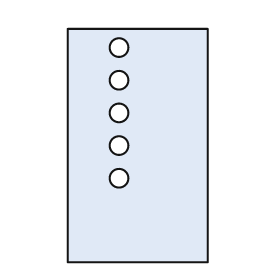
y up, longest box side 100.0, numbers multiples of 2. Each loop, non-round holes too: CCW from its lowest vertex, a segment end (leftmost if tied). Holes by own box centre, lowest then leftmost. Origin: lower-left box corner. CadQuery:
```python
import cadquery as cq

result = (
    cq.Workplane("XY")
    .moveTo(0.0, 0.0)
    .lineTo(60.0, 0.0)
    .lineTo(60.0, 100.0)
    .lineTo(0.0, 100.0)
    .close()
    .moveTo(22.0, 36.0)
    .circle(4.0)
    .moveTo(22.0, 50.0)
    .circle(4.0)
    .moveTo(22.0, 64.0)
    .circle(4.0)
    .moveTo(22.0, 78.0)
    .circle(4.0)
    .moveTo(22.0, 92.0)
    .circle(4.0)
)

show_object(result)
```